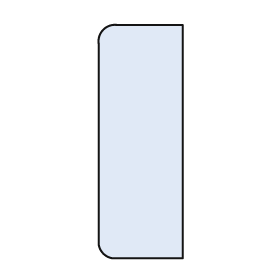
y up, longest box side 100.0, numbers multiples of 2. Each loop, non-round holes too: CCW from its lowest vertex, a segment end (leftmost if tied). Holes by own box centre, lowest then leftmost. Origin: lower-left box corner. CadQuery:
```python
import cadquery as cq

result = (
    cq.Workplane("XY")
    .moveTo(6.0, 0.0)
    .lineTo(36.0, 0.0)
    .lineTo(36.0, 100.0)
    .lineTo(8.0, 100.0)
    .threePointArc((2.0, 98.0), (0.0, 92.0))
    .lineTo(0.0, 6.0)
    .threePointArc((2.0, 2.0), (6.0, 0.0))
    .close()
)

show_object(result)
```